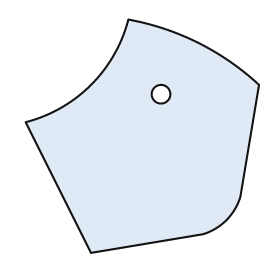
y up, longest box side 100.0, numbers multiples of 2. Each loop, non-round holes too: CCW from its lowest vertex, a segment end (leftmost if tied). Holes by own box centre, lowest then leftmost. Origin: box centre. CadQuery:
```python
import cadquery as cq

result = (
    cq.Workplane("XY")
    .moveTo(-22.0, -50.0)
    .lineTo(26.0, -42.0)
    .threePointArc((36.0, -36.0), (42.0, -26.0))
    .lineTo(50.0, 22.0)
    .threePointArc((24.0, 40.0), (-6.0, 50.0))
    .threePointArc((-22.0, 22.0), (-50.0, 6.0))
    .close()
    .moveTo(8.0, 18.0)
    .circle(4.0)
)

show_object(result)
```